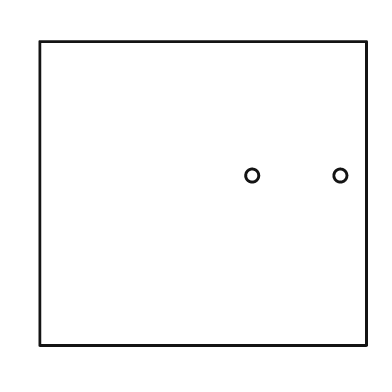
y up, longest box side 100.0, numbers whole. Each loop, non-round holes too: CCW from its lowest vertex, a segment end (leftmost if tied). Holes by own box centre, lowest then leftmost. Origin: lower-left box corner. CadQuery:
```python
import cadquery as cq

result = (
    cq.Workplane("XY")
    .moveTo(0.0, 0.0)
    .lineTo(100.0, 0.0)
    .lineTo(100.0, 93.0)
    .lineTo(0.0, 93.0)
    .close()
    .moveTo(65.0, 52.0)
    .circle(2.0)
    .moveTo(92.0, 52.0)
    .circle(2.0)
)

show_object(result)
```